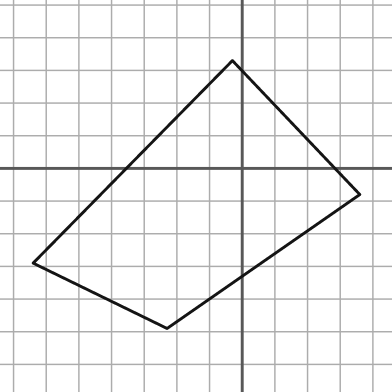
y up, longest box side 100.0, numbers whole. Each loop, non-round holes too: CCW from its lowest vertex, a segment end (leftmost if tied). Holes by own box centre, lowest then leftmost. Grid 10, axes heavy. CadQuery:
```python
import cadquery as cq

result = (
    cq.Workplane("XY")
    .moveTo(-23.0, -49.0)
    .lineTo(36.0, -8.0)
    .lineTo(-3.0, 33.0)
    .lineTo(-64.0, -29.0)
    .close()
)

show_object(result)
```